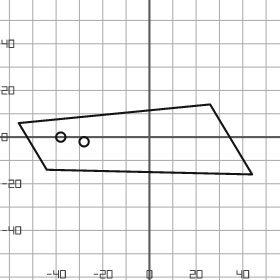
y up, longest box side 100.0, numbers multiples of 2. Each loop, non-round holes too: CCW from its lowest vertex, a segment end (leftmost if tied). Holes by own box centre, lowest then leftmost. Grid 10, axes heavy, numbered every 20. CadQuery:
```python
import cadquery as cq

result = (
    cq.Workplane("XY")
    .moveTo(44.0, -16.0)
    .lineTo(26.0, 14.0)
    .lineTo(-56.0, 6.0)
    .lineTo(-44.0, -14.0)
    .close()
    .moveTo(-28.0, -2.0)
    .circle(2.0)
    .moveTo(-38.0, 0.0)
    .circle(2.0)
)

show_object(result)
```